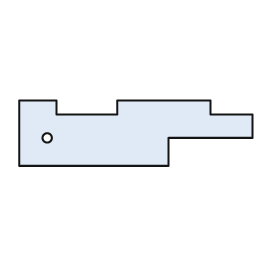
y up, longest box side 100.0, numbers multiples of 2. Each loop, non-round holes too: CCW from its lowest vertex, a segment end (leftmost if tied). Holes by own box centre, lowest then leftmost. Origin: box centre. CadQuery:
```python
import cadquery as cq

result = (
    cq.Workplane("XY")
    .moveTo(-50.0, -14.0)
    .lineTo(14.0, -14.0)
    .lineTo(14.0, -2.0)
    .lineTo(50.0, -2.0)
    .lineTo(50.0, 8.0)
    .lineTo(32.0, 8.0)
    .lineTo(32.0, 14.0)
    .lineTo(-8.0, 14.0)
    .lineTo(-8.0, 8.0)
    .lineTo(-34.0, 8.0)
    .lineTo(-34.0, 14.0)
    .lineTo(-50.0, 14.0)
    .close()
    .moveTo(-38.0, -2.0)
    .circle(2.0)
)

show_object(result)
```